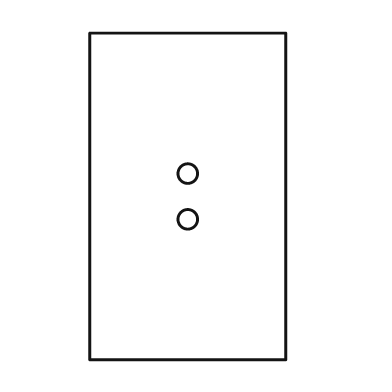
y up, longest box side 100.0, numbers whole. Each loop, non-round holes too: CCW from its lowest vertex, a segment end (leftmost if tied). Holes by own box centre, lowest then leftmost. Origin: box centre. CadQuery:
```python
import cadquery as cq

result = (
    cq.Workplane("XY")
    .moveTo(-30.0, -50.0)
    .lineTo(30.0, -50.0)
    .lineTo(30.0, 50.0)
    .lineTo(-30.0, 50.0)
    .close()
    .moveTo(0.0, -7.0)
    .circle(3.0)
    .moveTo(0.0, 7.0)
    .circle(3.0)
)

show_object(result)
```